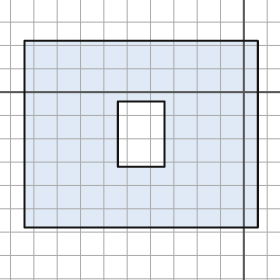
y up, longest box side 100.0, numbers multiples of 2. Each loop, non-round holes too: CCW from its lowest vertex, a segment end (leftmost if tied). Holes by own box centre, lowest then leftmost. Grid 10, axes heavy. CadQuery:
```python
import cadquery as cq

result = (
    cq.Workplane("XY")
    .moveTo(-94.0, -58.0)
    .lineTo(6.0, -58.0)
    .lineTo(6.0, 22.0)
    .lineTo(-94.0, 22.0)
    .close()
    .moveTo(-54.0, -32.0)
    .lineTo(-34.0, -32.0)
    .lineTo(-34.0, -4.0)
    .lineTo(-54.0, -4.0)
    .close()
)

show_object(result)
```